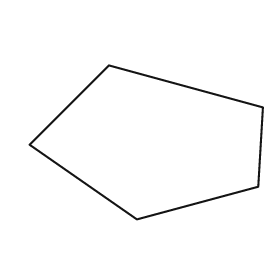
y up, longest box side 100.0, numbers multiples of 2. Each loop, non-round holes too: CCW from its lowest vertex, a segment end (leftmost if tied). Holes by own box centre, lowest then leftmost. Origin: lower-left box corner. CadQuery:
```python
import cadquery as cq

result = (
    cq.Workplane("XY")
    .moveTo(46.0, 0.0)
    .lineTo(98.0, 14.0)
    .lineTo(100.0, 48.0)
    .lineTo(34.0, 66.0)
    .lineTo(0.0, 32.0)
    .close()
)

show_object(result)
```